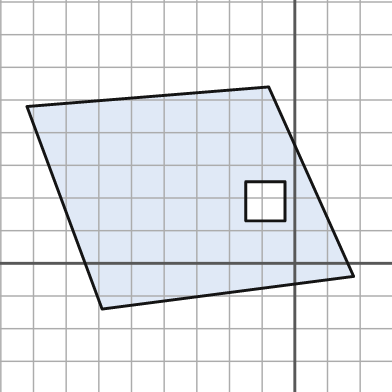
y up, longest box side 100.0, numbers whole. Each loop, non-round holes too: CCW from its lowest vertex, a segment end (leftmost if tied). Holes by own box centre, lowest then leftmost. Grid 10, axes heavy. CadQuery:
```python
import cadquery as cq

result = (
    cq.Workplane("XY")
    .moveTo(-59.0, -14.0)
    .lineTo(18.0, -4.0)
    .lineTo(-8.0, 54.0)
    .lineTo(-82.0, 48.0)
    .close()
    .moveTo(-15.0, 13.0)
    .lineTo(-3.0, 13.0)
    .lineTo(-3.0, 25.0)
    .lineTo(-15.0, 25.0)
    .close()
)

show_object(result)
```